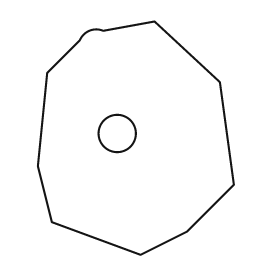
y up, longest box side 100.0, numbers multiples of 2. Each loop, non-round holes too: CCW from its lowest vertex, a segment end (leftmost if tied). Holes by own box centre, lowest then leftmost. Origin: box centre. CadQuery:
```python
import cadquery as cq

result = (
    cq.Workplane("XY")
    .moveTo(2.0, -50.0)
    .lineTo(22.0, -40.0)
    .lineTo(42.0, -20.0)
    .lineTo(36.0, 24.0)
    .lineTo(8.0, 50.0)
    .lineTo(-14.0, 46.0)
    .threePointArc((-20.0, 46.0), (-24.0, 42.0))
    .lineTo(-38.0, 28.0)
    .lineTo(-42.0, -12.0)
    .lineTo(-36.0, -36.0)
    .close()
    .moveTo(-8.0, 2.0)
    .circle(8.0)
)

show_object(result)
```